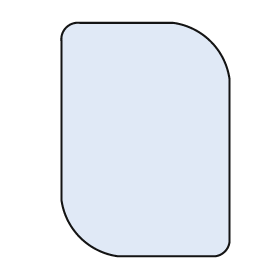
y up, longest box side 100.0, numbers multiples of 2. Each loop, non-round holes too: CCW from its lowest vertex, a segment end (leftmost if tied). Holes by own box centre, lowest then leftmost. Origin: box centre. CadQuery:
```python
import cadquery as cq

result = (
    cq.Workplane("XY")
    .moveTo(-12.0, -50.0)
    .lineTo(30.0, -50.0)
    .threePointArc((34.0, -48.0), (36.0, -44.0))
    .lineTo(36.0, 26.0)
    .threePointArc((28.0, 42.0), (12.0, 50.0))
    .lineTo(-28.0, 50.0)
    .threePointArc((-34.0, 48.0), (-36.0, 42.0))
    .lineTo(-36.0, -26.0)
    .threePointArc((-28.0, -42.0), (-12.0, -50.0))
    .close()
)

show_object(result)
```